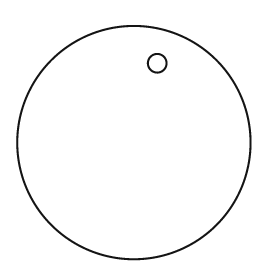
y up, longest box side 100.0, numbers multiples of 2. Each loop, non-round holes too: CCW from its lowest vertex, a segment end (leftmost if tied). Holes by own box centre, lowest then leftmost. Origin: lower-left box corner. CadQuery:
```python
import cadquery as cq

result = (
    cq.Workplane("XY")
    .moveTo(50.0, 50.0)
    .circle(50.0)
    .moveTo(60.0, 84.0)
    .circle(4.0)
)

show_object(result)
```